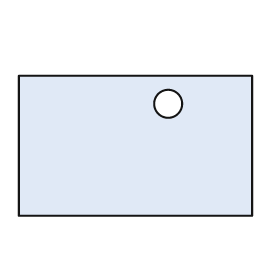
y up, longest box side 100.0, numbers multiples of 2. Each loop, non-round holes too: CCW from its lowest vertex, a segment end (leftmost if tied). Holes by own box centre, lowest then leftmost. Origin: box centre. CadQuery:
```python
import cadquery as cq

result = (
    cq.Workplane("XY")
    .moveTo(-50.0, -30.0)
    .lineTo(50.0, -30.0)
    .lineTo(50.0, 30.0)
    .lineTo(-50.0, 30.0)
    .close()
    .moveTo(14.0, 18.0)
    .circle(6.0)
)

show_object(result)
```